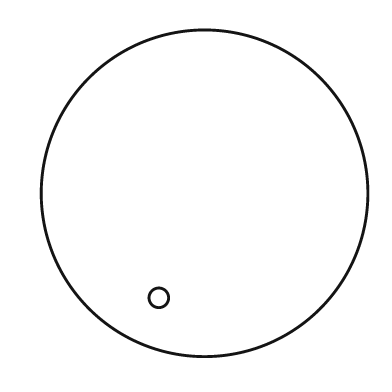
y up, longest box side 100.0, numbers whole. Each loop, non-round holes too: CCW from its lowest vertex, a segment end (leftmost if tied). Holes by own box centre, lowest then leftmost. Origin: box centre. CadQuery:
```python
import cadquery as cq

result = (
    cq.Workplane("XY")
    .moveTo(0.0, 0.0)
    .circle(50.0)
    .moveTo(-14.0, -32.0)
    .circle(3.0)
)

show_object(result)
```